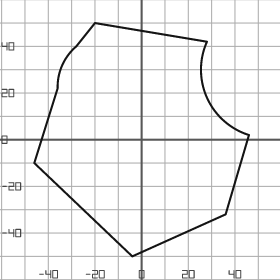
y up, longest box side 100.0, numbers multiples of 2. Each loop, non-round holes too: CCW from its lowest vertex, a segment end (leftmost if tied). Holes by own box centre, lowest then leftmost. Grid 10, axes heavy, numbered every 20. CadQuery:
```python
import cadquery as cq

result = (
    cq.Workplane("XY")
    .moveTo(-4.0, -50.0)
    .lineTo(36.0, -32.0)
    .lineTo(46.0, 2.0)
    .threePointArc((28.0, 18.0), (28.0, 42.0))
    .lineTo(-20.0, 50.0)
    .lineTo(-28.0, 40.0)
    .threePointArc((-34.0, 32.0), (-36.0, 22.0))
    .lineTo(-46.0, -10.0)
    .close()
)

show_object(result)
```